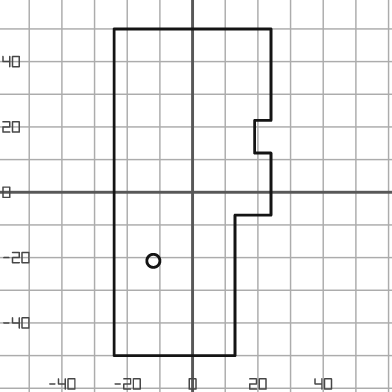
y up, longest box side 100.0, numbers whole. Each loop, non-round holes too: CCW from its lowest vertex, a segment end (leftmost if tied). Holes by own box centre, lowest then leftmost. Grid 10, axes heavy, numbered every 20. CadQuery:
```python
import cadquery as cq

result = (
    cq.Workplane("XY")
    .moveTo(-24.0, -50.0)
    .lineTo(13.0, -50.0)
    .lineTo(13.0, -7.0)
    .lineTo(24.0, -7.0)
    .lineTo(24.0, 12.0)
    .lineTo(19.0, 12.0)
    .lineTo(19.0, 22.0)
    .lineTo(24.0, 22.0)
    .lineTo(24.0, 50.0)
    .lineTo(-24.0, 50.0)
    .close()
    .moveTo(-12.0, -21.0)
    .circle(2.0)
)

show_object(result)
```